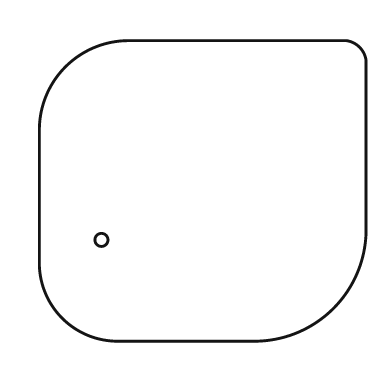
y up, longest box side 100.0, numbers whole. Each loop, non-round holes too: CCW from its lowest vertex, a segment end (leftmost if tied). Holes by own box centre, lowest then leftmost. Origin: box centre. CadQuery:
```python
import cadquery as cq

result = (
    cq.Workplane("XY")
    .moveTo(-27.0, -46.0)
    .lineTo(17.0, -46.0)
    .threePointArc((40.0, -36.0), (50.0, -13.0))
    .lineTo(50.0, 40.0)
    .threePointArc((48.0, 44.0), (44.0, 46.0))
    .lineTo(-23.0, 46.0)
    .threePointArc((-42.0, 38.0), (-50.0, 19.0))
    .lineTo(-50.0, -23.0)
    .threePointArc((-43.0, -39.0), (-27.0, -46.0))
    .close()
    .moveTo(-31.0, -15.0)
    .circle(2.0)
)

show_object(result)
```